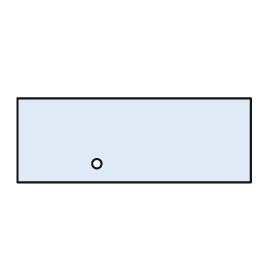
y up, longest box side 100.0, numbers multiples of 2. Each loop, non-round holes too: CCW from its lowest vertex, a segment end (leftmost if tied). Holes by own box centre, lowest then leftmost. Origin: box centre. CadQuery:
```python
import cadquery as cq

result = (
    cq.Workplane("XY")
    .moveTo(-50.0, -18.0)
    .lineTo(50.0, -18.0)
    .lineTo(50.0, 18.0)
    .lineTo(-50.0, 18.0)
    .close()
    .moveTo(-16.0, -10.0)
    .circle(2.0)
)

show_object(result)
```